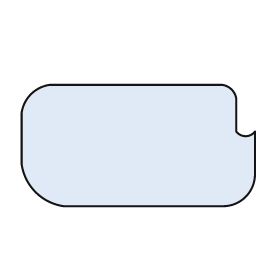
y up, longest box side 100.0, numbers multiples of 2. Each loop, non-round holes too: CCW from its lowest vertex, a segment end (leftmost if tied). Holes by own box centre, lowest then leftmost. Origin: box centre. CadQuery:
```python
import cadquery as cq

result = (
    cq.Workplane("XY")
    .moveTo(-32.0, -26.0)
    .lineTo(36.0, -26.0)
    .threePointArc((46.0, -22.0), (50.0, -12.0))
    .lineTo(50.0, 6.0)
    .threePointArc((46.0, 4.0), (42.0, 6.0))
    .lineTo(42.0, 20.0)
    .threePointArc((40.0, 24.0), (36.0, 26.0))
    .lineTo(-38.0, 26.0)
    .threePointArc((-46.0, 22.0), (-50.0, 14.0))
    .lineTo(-50.0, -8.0)
    .threePointArc((-44.0, -20.0), (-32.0, -26.0))
    .close()
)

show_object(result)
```